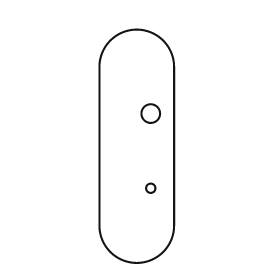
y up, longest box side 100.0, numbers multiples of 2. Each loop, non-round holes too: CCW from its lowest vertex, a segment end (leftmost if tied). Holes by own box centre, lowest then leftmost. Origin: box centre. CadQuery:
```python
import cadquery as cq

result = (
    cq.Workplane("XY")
    .moveTo(-16.0, -34.0)
    .threePointArc((0.0, -50.0), (16.0, -34.0))
    .lineTo(16.0, 34.0)
    .threePointArc((0.0, 50.0), (-16.0, 34.0))
    .close()
    .moveTo(6.0, -18.0)
    .circle(2.0)
    .moveTo(6.0, 14.0)
    .circle(4.0)
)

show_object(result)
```